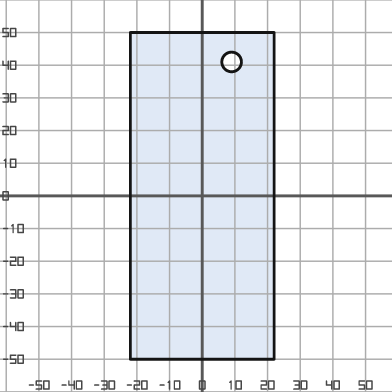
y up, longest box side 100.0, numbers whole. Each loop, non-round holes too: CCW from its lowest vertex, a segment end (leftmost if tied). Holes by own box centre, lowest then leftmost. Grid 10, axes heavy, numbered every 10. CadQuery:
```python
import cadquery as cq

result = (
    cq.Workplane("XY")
    .moveTo(-22.0, -50.0)
    .lineTo(22.0, -50.0)
    .lineTo(22.0, 50.0)
    .lineTo(-22.0, 50.0)
    .close()
    .moveTo(9.0, 41.0)
    .circle(3.0)
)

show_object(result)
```